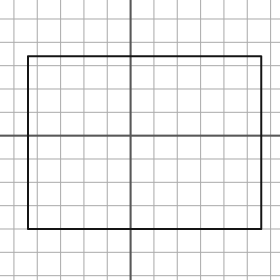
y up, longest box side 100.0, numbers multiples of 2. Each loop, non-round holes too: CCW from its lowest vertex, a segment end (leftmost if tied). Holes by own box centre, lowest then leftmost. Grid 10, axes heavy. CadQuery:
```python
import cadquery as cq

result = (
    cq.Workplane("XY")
    .moveTo(-44.0, -40.0)
    .lineTo(56.0, -40.0)
    .lineTo(56.0, 34.0)
    .lineTo(-44.0, 34.0)
    .close()
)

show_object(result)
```